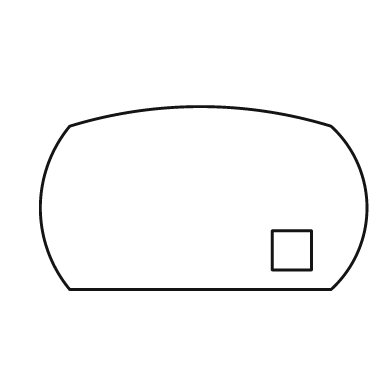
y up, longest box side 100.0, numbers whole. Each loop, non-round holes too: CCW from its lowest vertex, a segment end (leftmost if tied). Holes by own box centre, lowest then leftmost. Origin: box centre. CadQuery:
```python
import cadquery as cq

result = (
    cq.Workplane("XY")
    .moveTo(-41.0, -28.0)
    .lineTo(39.0, -28.0)
    .threePointArc((50.0, -3.0), (39.0, 22.0))
    .threePointArc((-1.0, 28.0), (-41.0, 22.0))
    .threePointArc((-50.0, -3.0), (-41.0, -28.0))
    .close()
    .moveTo(21.0, -22.0)
    .lineTo(33.0, -22.0)
    .lineTo(33.0, -10.0)
    .lineTo(21.0, -10.0)
    .close()
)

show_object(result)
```